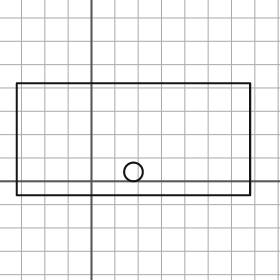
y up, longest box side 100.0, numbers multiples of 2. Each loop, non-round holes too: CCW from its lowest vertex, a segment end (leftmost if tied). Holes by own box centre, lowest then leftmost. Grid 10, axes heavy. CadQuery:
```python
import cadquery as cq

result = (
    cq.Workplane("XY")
    .moveTo(-32.0, -6.0)
    .lineTo(68.0, -6.0)
    .lineTo(68.0, 42.0)
    .lineTo(-32.0, 42.0)
    .close()
    .moveTo(18.0, 4.0)
    .circle(4.0)
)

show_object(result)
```